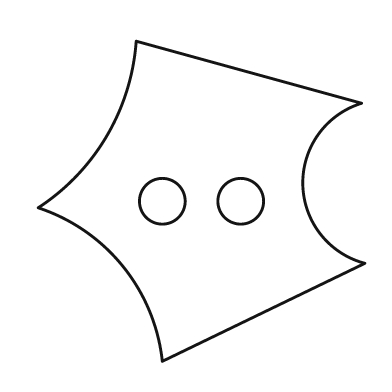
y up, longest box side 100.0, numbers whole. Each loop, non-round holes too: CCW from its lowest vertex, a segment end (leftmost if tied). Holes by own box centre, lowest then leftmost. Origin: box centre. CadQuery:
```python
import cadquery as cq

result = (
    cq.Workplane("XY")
    .moveTo(-12.0, -49.0)
    .lineTo(50.0, -19.0)
    .threePointArc((31.0, 5.0), (49.0, 30.0))
    .lineTo(-20.0, 49.0)
    .threePointArc((-29.0, 20.0), (-50.0, -2.0))
    .threePointArc((-24.0, -20.0), (-12.0, -49.0))
    .close()
    .moveTo(-12.0, 0.0)
    .circle(7.0)
    .moveTo(12.0, 0.0)
    .circle(7.0)
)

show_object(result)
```